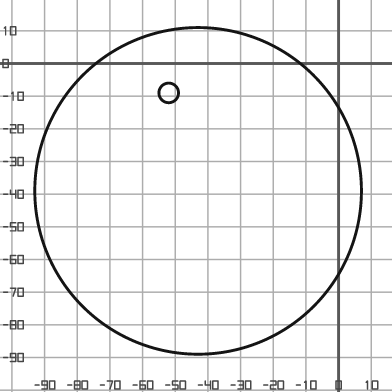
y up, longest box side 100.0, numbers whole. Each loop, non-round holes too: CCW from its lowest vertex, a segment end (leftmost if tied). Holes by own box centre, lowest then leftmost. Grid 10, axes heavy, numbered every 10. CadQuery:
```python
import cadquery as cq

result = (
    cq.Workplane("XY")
    .moveTo(-43.0, -39.0)
    .circle(50.0)
    .moveTo(-52.0, -9.0)
    .circle(3.0)
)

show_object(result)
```